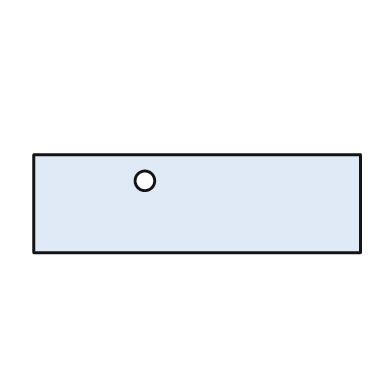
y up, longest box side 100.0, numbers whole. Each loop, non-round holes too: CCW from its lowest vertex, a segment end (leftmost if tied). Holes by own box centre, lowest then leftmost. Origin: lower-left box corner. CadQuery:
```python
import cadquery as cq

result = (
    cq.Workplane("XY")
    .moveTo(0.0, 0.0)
    .lineTo(100.0, 0.0)
    .lineTo(100.0, 30.0)
    .lineTo(0.0, 30.0)
    .close()
    .moveTo(34.0, 22.0)
    .circle(3.0)
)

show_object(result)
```